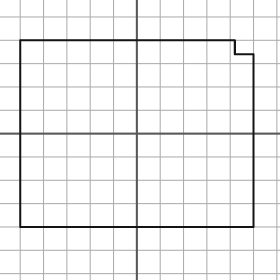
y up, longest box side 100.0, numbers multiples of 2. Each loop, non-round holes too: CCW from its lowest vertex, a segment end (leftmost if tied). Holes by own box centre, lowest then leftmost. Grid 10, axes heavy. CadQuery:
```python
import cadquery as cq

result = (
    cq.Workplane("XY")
    .moveTo(-50.0, -40.0)
    .lineTo(50.0, -40.0)
    .lineTo(50.0, 34.0)
    .lineTo(42.0, 34.0)
    .lineTo(42.0, 40.0)
    .lineTo(-50.0, 40.0)
    .close()
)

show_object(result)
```